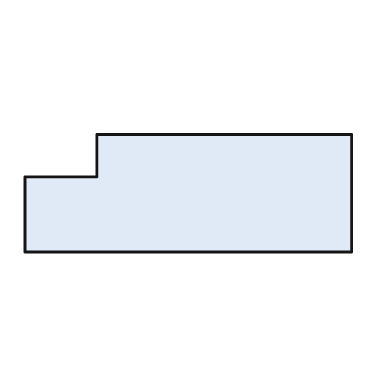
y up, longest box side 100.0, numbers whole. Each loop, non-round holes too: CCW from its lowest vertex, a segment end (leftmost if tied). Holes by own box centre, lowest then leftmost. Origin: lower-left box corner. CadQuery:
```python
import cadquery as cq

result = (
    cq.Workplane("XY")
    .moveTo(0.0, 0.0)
    .lineTo(100.0, 0.0)
    .lineTo(100.0, 36.0)
    .lineTo(22.0, 36.0)
    .lineTo(22.0, 23.0)
    .lineTo(0.0, 23.0)
    .close()
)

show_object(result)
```